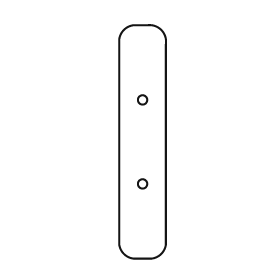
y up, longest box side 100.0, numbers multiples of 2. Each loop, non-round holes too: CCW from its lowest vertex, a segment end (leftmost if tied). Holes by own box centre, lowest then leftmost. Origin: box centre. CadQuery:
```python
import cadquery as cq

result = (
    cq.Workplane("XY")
    .moveTo(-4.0, -50.0)
    .lineTo(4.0, -50.0)
    .threePointArc((8.0, -48.0), (10.0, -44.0))
    .lineTo(10.0, 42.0)
    .threePointArc((8.0, 48.0), (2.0, 50.0))
    .lineTo(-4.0, 50.0)
    .threePointArc((-8.0, 48.0), (-10.0, 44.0))
    .lineTo(-10.0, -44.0)
    .threePointArc((-8.0, -48.0), (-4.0, -50.0))
    .close()
    .moveTo(0.0, -18.0)
    .circle(2.0)
    .moveTo(0.0, 18.0)
    .circle(2.0)
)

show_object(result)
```